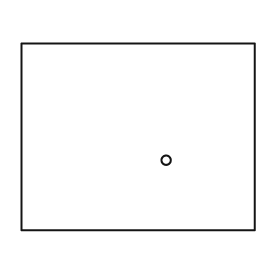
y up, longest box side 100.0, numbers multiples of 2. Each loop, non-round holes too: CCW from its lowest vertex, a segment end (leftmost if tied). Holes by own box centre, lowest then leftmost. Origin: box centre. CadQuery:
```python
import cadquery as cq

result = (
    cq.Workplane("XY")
    .moveTo(-50.0, -40.0)
    .lineTo(50.0, -40.0)
    .lineTo(50.0, 40.0)
    .lineTo(-50.0, 40.0)
    .close()
    .moveTo(12.0, -10.0)
    .circle(2.0)
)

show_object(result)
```